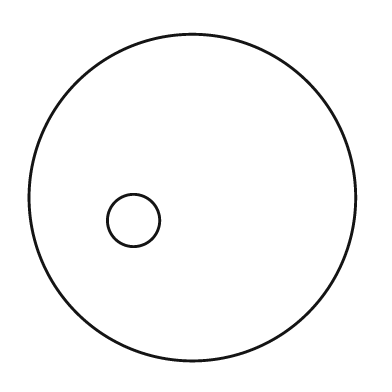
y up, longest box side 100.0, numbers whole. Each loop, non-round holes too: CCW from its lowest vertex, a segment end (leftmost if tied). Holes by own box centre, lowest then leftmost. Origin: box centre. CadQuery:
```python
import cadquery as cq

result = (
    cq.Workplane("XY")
    .moveTo(0.0, 0.0)
    .circle(50.0)
    .moveTo(-18.0, -7.0)
    .circle(8.0)
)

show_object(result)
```